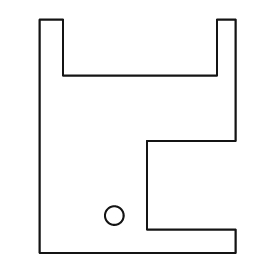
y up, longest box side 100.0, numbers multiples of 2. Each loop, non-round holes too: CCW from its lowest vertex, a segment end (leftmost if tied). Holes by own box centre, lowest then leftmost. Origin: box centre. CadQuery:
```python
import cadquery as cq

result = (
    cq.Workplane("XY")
    .moveTo(-42.0, -50.0)
    .lineTo(42.0, -50.0)
    .lineTo(42.0, -40.0)
    .lineTo(4.0, -40.0)
    .lineTo(4.0, -2.0)
    .lineTo(42.0, -2.0)
    .lineTo(42.0, 50.0)
    .lineTo(34.0, 50.0)
    .lineTo(34.0, 26.0)
    .lineTo(-32.0, 26.0)
    .lineTo(-32.0, 50.0)
    .lineTo(-42.0, 50.0)
    .close()
    .moveTo(-10.0, -34.0)
    .circle(4.0)
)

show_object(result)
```